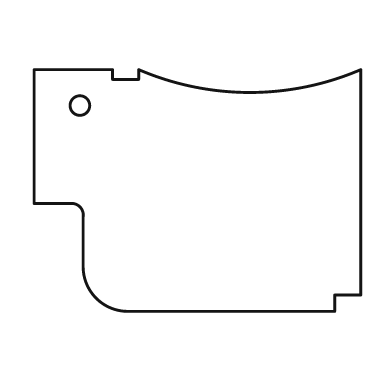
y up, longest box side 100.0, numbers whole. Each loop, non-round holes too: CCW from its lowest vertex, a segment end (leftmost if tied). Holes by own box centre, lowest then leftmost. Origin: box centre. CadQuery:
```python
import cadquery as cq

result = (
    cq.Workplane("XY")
    .moveTo(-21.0, -37.0)
    .lineTo(42.0, -37.0)
    .lineTo(42.0, -32.0)
    .lineTo(50.0, -32.0)
    .lineTo(50.0, 37.0)
    .threePointArc((16.0, 30.0), (-18.0, 37.0))
    .lineTo(-18.0, 34.0)
    .lineTo(-26.0, 34.0)
    .lineTo(-26.0, 37.0)
    .lineTo(-50.0, 37.0)
    .lineTo(-50.0, -4.0)
    .lineTo(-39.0, -4.0)
    .threePointArc((-36.0, -5.0), (-35.0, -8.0))
    .lineTo(-35.0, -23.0)
    .threePointArc((-31.0, -33.0), (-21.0, -37.0))
    .close()
    .moveTo(-36.0, 26.0)
    .circle(3.0)
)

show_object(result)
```